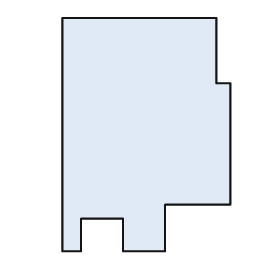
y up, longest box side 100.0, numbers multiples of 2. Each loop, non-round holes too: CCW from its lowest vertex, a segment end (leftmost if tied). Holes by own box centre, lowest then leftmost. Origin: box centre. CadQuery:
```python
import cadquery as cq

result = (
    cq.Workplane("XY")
    .moveTo(-36.0, -50.0)
    .lineTo(-28.0, -50.0)
    .lineTo(-28.0, -36.0)
    .lineTo(-10.0, -36.0)
    .lineTo(-10.0, -50.0)
    .lineTo(8.0, -50.0)
    .lineTo(8.0, -30.0)
    .lineTo(36.0, -30.0)
    .lineTo(36.0, 22.0)
    .lineTo(30.0, 22.0)
    .lineTo(30.0, 50.0)
    .lineTo(-36.0, 50.0)
    .close()
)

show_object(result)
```